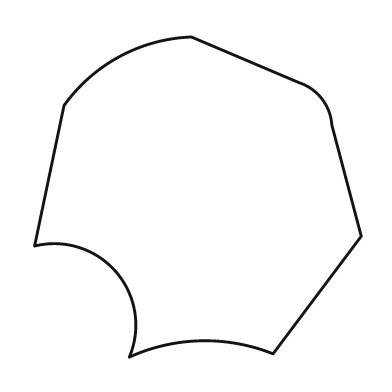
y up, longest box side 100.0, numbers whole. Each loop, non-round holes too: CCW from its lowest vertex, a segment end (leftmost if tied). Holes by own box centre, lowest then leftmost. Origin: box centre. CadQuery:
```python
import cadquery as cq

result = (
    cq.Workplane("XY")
    .moveTo(-21.0, -49.0)
    .threePointArc((1.0, -44.0), (23.0, -48.0))
    .lineTo(50.0, -12.0)
    .lineTo(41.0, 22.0)
    .threePointArc((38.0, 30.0), (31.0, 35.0))
    .lineTo(-2.0, 49.0)
    .threePointArc((-24.0, 43.0), (-41.0, 28.0))
    .lineTo(-50.0, -15.0)
    .threePointArc((-25.0, -23.0), (-21.0, -49.0))
    .close()
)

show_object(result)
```